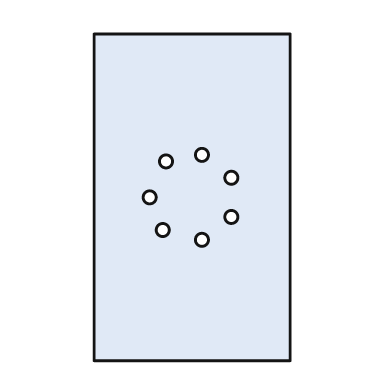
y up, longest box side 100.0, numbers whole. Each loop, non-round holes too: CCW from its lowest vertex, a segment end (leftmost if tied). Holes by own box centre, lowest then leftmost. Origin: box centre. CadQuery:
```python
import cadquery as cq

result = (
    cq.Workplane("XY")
    .moveTo(-30.0, -50.0)
    .lineTo(30.0, -50.0)
    .lineTo(30.0, 50.0)
    .lineTo(-30.0, 50.0)
    .close()
    .moveTo(3.0, -13.0)
    .circle(2.0)
    .moveTo(-9.0, -10.0)
    .circle(2.0)
    .moveTo(12.0, -6.0)
    .circle(2.0)
    .moveTo(-13.0, 0.0)
    .circle(2.0)
    .moveTo(12.0, 6.0)
    .circle(2.0)
    .moveTo(-8.0, 11.0)
    .circle(2.0)
    .moveTo(3.0, 13.0)
    .circle(2.0)
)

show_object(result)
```